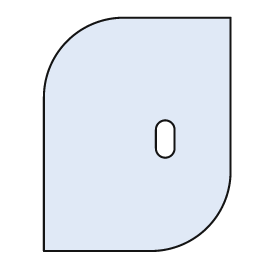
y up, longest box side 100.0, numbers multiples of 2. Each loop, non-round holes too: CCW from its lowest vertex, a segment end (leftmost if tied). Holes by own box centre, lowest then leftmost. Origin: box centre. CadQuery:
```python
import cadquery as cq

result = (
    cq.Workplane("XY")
    .moveTo(-40.0, -50.0)
    .lineTo(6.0, -50.0)
    .threePointArc((30.0, -40.0), (40.0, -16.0))
    .lineTo(40.0, 50.0)
    .lineTo(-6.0, 50.0)
    .threePointArc((-30.0, 40.0), (-40.0, 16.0))
    .close()
    .moveTo(8.0, -6.0)
    .threePointArc((12.0, -10.0), (16.0, -6.0))
    .lineTo(16.0, 2.0)
    .threePointArc((12.0, 6.0), (8.0, 2.0))
    .close()
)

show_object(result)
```